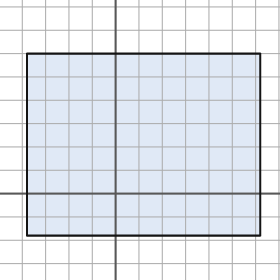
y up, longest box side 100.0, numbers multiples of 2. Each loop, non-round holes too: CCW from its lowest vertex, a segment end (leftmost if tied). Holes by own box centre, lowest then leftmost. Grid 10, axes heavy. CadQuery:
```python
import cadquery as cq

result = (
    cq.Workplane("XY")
    .moveTo(-38.0, -18.0)
    .lineTo(62.0, -18.0)
    .lineTo(62.0, 60.0)
    .lineTo(-38.0, 60.0)
    .close()
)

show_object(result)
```